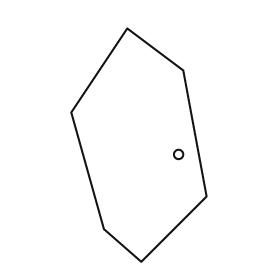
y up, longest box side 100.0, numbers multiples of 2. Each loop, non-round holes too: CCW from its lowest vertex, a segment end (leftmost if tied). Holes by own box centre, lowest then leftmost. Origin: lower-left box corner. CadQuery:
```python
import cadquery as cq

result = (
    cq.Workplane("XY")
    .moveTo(30.0, 0.0)
    .lineTo(58.0, 28.0)
    .lineTo(48.0, 82.0)
    .lineTo(24.0, 100.0)
    .lineTo(0.0, 64.0)
    .lineTo(14.0, 14.0)
    .close()
    .moveTo(46.0, 46.0)
    .circle(2.0)
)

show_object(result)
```